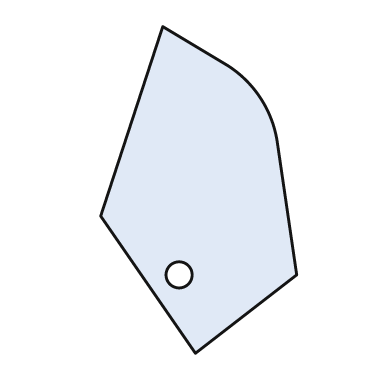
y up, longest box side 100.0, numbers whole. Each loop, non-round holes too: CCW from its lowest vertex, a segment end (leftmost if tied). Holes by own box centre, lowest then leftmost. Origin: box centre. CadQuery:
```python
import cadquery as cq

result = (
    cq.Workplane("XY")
    .moveTo(-1.0, -50.0)
    .lineTo(30.0, -26.0)
    .lineTo(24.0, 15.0)
    .threePointArc((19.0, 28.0), (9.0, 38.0))
    .lineTo(-11.0, 50.0)
    .lineTo(-30.0, -8.0)
    .close()
    .moveTo(-6.0, -26.0)
    .circle(4.0)
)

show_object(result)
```